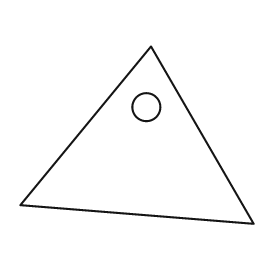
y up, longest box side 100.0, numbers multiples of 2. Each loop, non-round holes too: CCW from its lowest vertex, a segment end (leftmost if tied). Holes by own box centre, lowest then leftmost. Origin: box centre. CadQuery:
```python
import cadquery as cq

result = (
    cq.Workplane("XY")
    .moveTo(50.0, -38.0)
    .lineTo(6.0, 38.0)
    .lineTo(-50.0, -30.0)
    .close()
    .moveTo(4.0, 12.0)
    .circle(6.0)
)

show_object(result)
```